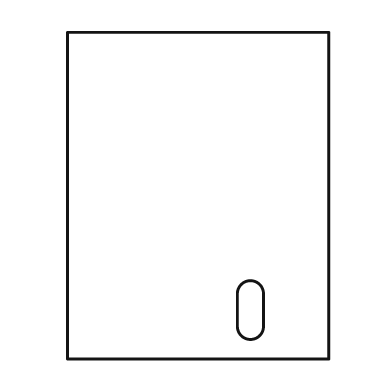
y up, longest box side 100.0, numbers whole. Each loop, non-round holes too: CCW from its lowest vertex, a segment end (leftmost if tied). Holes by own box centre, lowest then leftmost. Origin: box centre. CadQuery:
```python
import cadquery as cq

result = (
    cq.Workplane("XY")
    .moveTo(-40.0, -50.0)
    .lineTo(40.0, -50.0)
    .lineTo(40.0, 50.0)
    .lineTo(-40.0, 50.0)
    .close()
    .moveTo(12.0, -40.0)
    .threePointArc((16.0, -44.0), (20.0, -40.0))
    .lineTo(20.0, -30.0)
    .threePointArc((16.0, -26.0), (12.0, -30.0))
    .close()
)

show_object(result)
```